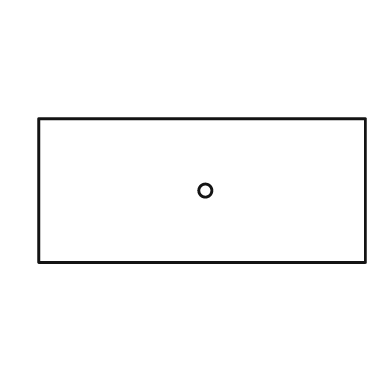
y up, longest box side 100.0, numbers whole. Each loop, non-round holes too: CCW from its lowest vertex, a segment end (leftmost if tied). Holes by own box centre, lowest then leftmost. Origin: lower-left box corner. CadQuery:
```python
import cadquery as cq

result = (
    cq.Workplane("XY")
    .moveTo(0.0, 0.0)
    .lineTo(100.0, 0.0)
    .lineTo(100.0, 44.0)
    .lineTo(0.0, 44.0)
    .close()
    .moveTo(51.0, 22.0)
    .circle(2.0)
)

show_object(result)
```